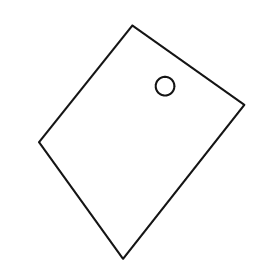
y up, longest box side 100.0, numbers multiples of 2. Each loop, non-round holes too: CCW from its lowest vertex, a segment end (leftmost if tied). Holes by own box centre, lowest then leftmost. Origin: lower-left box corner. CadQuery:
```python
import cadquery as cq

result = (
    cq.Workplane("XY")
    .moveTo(36.0, 0.0)
    .lineTo(88.0, 66.0)
    .lineTo(40.0, 100.0)
    .lineTo(0.0, 50.0)
    .close()
    .moveTo(54.0, 74.0)
    .circle(4.0)
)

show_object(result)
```